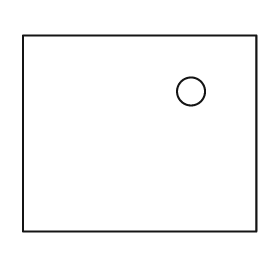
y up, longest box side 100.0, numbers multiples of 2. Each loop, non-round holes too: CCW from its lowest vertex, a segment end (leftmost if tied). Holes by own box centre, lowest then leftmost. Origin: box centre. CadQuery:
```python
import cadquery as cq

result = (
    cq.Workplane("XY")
    .moveTo(-50.0, -42.0)
    .lineTo(50.0, -42.0)
    .lineTo(50.0, 42.0)
    .lineTo(-50.0, 42.0)
    .close()
    .moveTo(22.0, 18.0)
    .circle(6.0)
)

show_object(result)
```